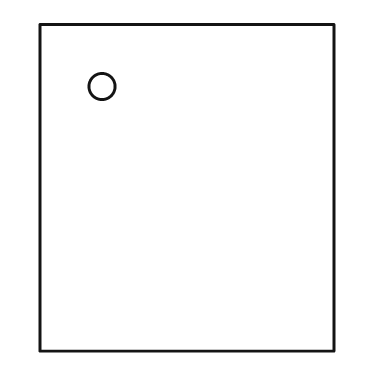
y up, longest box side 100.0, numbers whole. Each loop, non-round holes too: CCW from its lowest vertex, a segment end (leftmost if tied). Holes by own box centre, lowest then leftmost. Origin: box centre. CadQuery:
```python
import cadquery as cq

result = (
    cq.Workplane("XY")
    .moveTo(-45.0, -50.0)
    .lineTo(45.0, -50.0)
    .lineTo(45.0, 50.0)
    .lineTo(-45.0, 50.0)
    .close()
    .moveTo(-26.0, 31.0)
    .circle(4.0)
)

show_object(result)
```